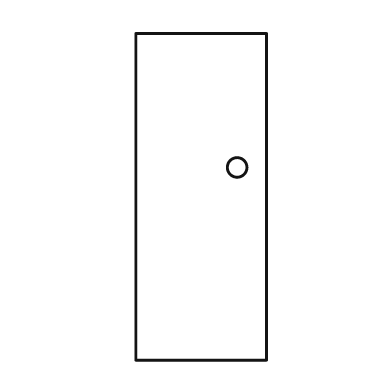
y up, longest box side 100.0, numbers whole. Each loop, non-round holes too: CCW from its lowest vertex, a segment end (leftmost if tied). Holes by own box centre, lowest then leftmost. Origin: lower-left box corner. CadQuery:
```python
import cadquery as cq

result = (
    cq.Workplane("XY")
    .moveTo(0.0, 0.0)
    .lineTo(40.0, 0.0)
    .lineTo(40.0, 100.0)
    .lineTo(0.0, 100.0)
    .close()
    .moveTo(31.0, 59.0)
    .circle(3.0)
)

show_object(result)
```